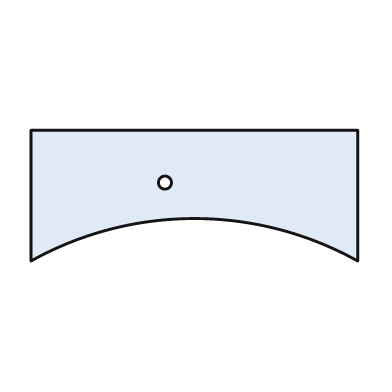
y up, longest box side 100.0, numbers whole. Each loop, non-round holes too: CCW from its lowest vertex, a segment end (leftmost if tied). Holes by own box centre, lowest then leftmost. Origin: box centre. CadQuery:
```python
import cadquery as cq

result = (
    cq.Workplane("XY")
    .moveTo(-50.0, -20.0)
    .threePointArc((0.0, -7.0), (50.0, -20.0))
    .lineTo(50.0, 20.0)
    .lineTo(-50.0, 20.0)
    .close()
    .moveTo(-9.0, 4.0)
    .circle(2.0)
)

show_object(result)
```